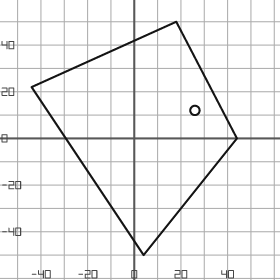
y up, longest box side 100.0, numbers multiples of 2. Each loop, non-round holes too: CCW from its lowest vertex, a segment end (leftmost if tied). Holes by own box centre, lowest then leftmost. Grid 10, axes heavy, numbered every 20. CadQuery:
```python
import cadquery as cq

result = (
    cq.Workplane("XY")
    .moveTo(4.0, -50.0)
    .lineTo(44.0, 0.0)
    .lineTo(18.0, 50.0)
    .lineTo(-44.0, 22.0)
    .close()
    .moveTo(26.0, 12.0)
    .circle(2.0)
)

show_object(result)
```